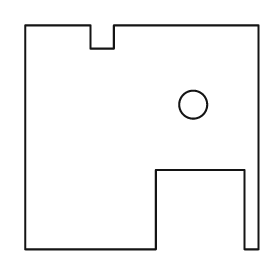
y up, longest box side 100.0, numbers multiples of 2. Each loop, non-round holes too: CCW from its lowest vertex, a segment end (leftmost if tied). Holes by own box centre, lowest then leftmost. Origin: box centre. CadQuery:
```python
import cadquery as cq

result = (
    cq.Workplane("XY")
    .moveTo(-50.0, -48.0)
    .lineTo(6.0, -48.0)
    .lineTo(6.0, -14.0)
    .lineTo(44.0, -14.0)
    .lineTo(44.0, -48.0)
    .lineTo(50.0, -48.0)
    .lineTo(50.0, 48.0)
    .lineTo(-12.0, 48.0)
    .lineTo(-12.0, 38.0)
    .lineTo(-22.0, 38.0)
    .lineTo(-22.0, 48.0)
    .lineTo(-50.0, 48.0)
    .close()
    .moveTo(22.0, 14.0)
    .circle(6.0)
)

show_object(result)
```